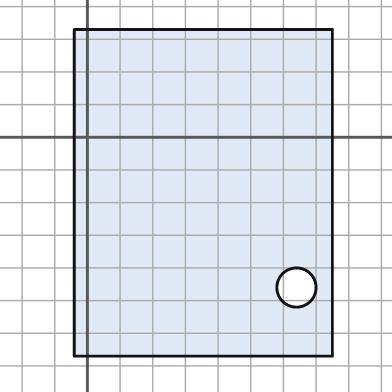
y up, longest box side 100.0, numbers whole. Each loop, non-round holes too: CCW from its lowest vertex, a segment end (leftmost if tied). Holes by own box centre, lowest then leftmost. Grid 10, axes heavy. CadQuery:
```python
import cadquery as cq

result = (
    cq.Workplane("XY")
    .moveTo(-4.0, -67.0)
    .lineTo(75.0, -67.0)
    .lineTo(75.0, 33.0)
    .lineTo(-4.0, 33.0)
    .close()
    .moveTo(64.0, -46.0)
    .circle(6.0)
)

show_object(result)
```